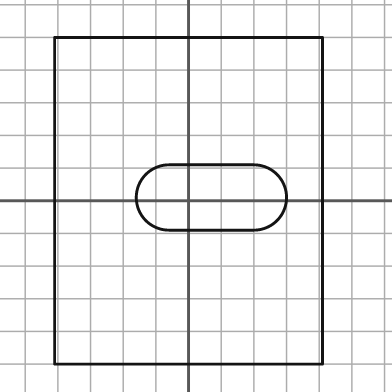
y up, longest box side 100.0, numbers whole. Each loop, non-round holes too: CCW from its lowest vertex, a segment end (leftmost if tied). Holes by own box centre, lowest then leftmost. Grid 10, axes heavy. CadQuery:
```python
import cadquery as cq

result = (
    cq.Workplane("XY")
    .moveTo(-41.0, -50.0)
    .lineTo(41.0, -50.0)
    .lineTo(41.0, 50.0)
    .lineTo(-41.0, 50.0)
    .close()
    .moveTo(-6.0, -9.0)
    .lineTo(20.0, -9.0)
    .threePointArc((30.0, 1.0), (20.0, 11.0))
    .lineTo(-6.0, 11.0)
    .threePointArc((-16.0, 1.0), (-6.0, -9.0))
    .close()
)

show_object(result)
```